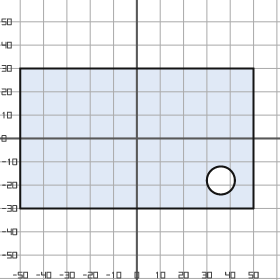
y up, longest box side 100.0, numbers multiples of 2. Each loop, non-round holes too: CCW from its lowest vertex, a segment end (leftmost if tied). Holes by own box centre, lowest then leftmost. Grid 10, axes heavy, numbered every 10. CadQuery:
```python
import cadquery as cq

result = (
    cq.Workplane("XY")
    .moveTo(-50.0, -30.0)
    .lineTo(50.0, -30.0)
    .lineTo(50.0, 30.0)
    .lineTo(-50.0, 30.0)
    .close()
    .moveTo(36.0, -18.0)
    .circle(6.0)
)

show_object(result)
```